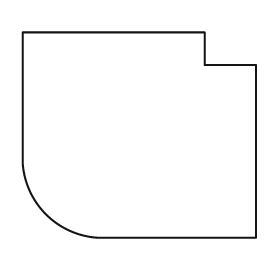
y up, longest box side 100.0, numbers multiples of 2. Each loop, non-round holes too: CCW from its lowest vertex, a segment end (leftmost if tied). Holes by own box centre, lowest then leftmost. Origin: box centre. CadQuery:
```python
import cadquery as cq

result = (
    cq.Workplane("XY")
    .moveTo(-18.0, -44.0)
    .lineTo(50.0, -44.0)
    .lineTo(50.0, 30.0)
    .lineTo(28.0, 30.0)
    .lineTo(28.0, 44.0)
    .lineTo(-50.0, 44.0)
    .lineTo(-50.0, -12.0)
    .threePointArc((-40.0, -34.0), (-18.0, -44.0))
    .close()
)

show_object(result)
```